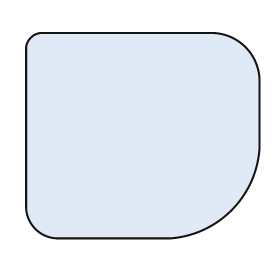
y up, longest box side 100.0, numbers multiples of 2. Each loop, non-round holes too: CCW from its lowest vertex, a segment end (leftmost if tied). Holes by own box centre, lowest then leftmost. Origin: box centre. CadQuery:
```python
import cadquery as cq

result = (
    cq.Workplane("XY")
    .moveTo(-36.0, -44.0)
    .lineTo(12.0, -44.0)
    .threePointArc((38.0, -32.0), (50.0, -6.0))
    .lineTo(50.0, 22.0)
    .threePointArc((44.0, 38.0), (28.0, 44.0))
    .lineTo(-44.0, 44.0)
    .threePointArc((-48.0, 42.0), (-50.0, 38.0))
    .lineTo(-50.0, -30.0)
    .threePointArc((-46.0, -40.0), (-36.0, -44.0))
    .close()
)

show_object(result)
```